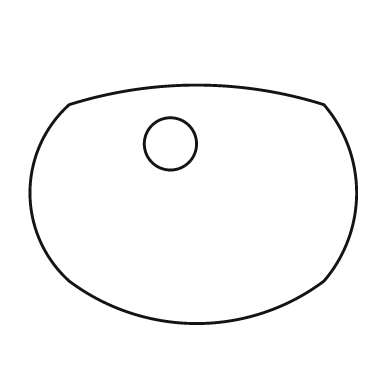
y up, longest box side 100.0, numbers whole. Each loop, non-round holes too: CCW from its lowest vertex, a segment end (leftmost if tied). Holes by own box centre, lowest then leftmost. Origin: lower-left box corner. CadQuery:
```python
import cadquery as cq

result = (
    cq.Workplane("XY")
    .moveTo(12.0, 13.0)
    .threePointArc((51.0, 0.0), (90.0, 13.0))
    .threePointArc((100.0, 40.0), (90.0, 67.0))
    .threePointArc((51.0, 73.0), (12.0, 67.0))
    .threePointArc((0.0, 40.0), (12.0, 13.0))
    .close()
    .moveTo(43.0, 55.0)
    .circle(8.0)
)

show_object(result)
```